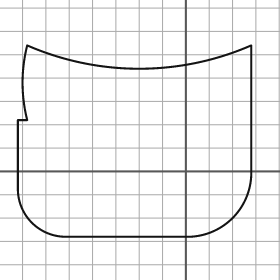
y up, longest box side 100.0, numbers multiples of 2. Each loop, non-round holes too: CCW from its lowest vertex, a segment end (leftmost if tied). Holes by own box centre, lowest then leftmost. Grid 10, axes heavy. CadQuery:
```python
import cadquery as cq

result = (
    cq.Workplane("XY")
    .moveTo(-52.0, -28.0)
    .lineTo(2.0, -28.0)
    .threePointArc((20.0, -20.0), (28.0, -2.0))
    .lineTo(28.0, 54.0)
    .threePointArc((-20.0, 44.0), (-68.0, 54.0))
    .threePointArc((-70.0, 38.0), (-68.0, 22.0))
    .lineTo(-72.0, 22.0)
    .lineTo(-72.0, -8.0)
    .threePointArc((-66.0, -22.0), (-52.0, -28.0))
    .close()
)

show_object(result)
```